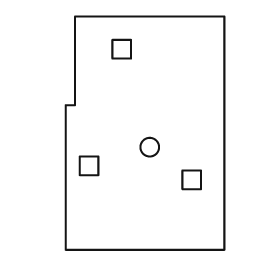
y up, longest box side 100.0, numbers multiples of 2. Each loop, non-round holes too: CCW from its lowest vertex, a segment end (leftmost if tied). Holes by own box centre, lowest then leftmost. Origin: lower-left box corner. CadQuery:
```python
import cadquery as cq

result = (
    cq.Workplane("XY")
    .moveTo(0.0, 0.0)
    .lineTo(68.0, 0.0)
    .lineTo(68.0, 100.0)
    .lineTo(4.0, 100.0)
    .lineTo(4.0, 62.0)
    .lineTo(0.0, 62.0)
    .close()
    .moveTo(50.0, 26.0)
    .lineTo(58.0, 26.0)
    .lineTo(58.0, 34.0)
    .lineTo(50.0, 34.0)
    .close()
    .moveTo(6.0, 32.0)
    .lineTo(14.0, 32.0)
    .lineTo(14.0, 40.0)
    .lineTo(6.0, 40.0)
    .close()
    .moveTo(36.0, 44.0)
    .circle(4.0)
    .moveTo(20.0, 82.0)
    .lineTo(28.0, 82.0)
    .lineTo(28.0, 90.0)
    .lineTo(20.0, 90.0)
    .close()
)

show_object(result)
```